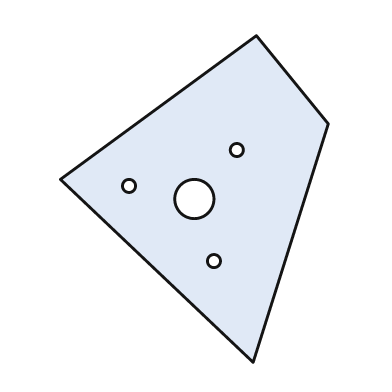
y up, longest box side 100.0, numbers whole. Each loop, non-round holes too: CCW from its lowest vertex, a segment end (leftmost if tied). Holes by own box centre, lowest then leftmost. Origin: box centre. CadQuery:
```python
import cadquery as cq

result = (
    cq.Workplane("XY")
    .moveTo(18.0, -50.0)
    .lineTo(41.0, 23.0)
    .lineTo(19.0, 50.0)
    .lineTo(-41.0, 6.0)
    .close()
    .moveTo(6.0, -19.0)
    .circle(2.0)
    .moveTo(0.0, 0.0)
    .circle(6.0)
    .moveTo(-20.0, 4.0)
    .circle(2.0)
    .moveTo(13.0, 15.0)
    .circle(2.0)
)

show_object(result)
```